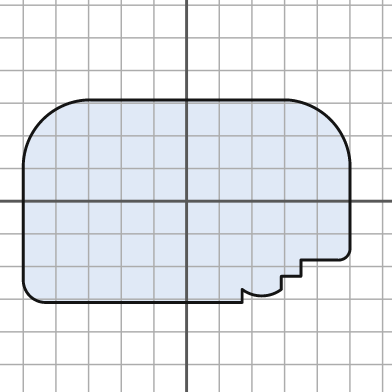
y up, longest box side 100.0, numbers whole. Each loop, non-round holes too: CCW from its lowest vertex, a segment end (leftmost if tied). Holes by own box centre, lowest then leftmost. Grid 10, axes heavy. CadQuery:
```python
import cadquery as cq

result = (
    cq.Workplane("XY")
    .moveTo(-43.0, -31.0)
    .lineTo(17.0, -31.0)
    .lineTo(17.0, -27.0)
    .threePointArc((23.0, -29.0), (29.0, -27.0))
    .lineTo(29.0, -23.0)
    .lineTo(35.0, -23.0)
    .lineTo(35.0, -18.0)
    .lineTo(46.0, -18.0)
    .threePointArc((49.0, -17.0), (50.0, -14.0))
    .lineTo(50.0, 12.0)
    .threePointArc((44.0, 25.0), (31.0, 31.0))
    .lineTo(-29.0, 31.0)
    .threePointArc((-44.0, 25.0), (-50.0, 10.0))
    .lineTo(-50.0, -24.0)
    .threePointArc((-48.0, -29.0), (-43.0, -31.0))
    .close()
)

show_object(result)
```